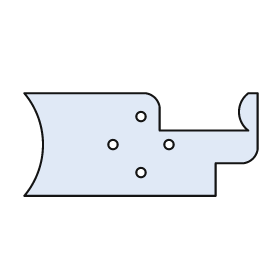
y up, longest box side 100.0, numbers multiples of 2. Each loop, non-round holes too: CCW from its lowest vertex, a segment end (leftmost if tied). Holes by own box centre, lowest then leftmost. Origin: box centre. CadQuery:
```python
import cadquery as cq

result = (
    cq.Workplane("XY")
    .moveTo(-50.0, -22.0)
    .lineTo(32.0, -22.0)
    .lineTo(32.0, -8.0)
    .lineTo(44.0, -8.0)
    .threePointArc((48.0, -6.0), (50.0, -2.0))
    .lineTo(50.0, 22.0)
    .lineTo(46.0, 22.0)
    .threePointArc((42.0, 14.0), (46.0, 6.0))
    .lineTo(8.0, 6.0)
    .lineTo(8.0, 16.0)
    .threePointArc((6.0, 20.0), (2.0, 22.0))
    .lineTo(-50.0, 22.0)
    .threePointArc((-42.0, 0.0), (-50.0, -22.0))
    .close()
    .moveTo(0.0, -12.0)
    .circle(2.0)
    .moveTo(-12.0, 0.0)
    .circle(2.0)
    .moveTo(12.0, 0.0)
    .circle(2.0)
    .moveTo(0.0, 12.0)
    .circle(2.0)
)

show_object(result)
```